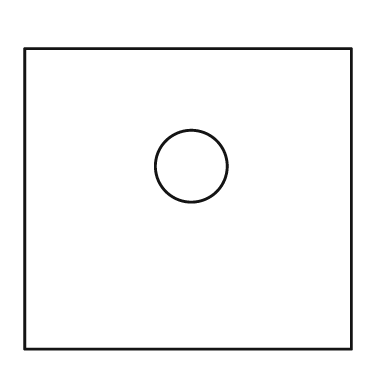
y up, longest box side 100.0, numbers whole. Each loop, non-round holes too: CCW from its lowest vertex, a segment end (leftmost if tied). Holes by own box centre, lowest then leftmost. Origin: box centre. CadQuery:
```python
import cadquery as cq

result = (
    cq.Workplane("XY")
    .moveTo(-50.0, -46.0)
    .lineTo(50.0, -46.0)
    .lineTo(50.0, 46.0)
    .lineTo(-50.0, 46.0)
    .close()
    .moveTo(1.0, 10.0)
    .circle(11.0)
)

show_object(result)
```